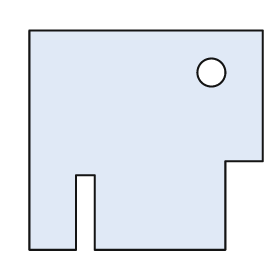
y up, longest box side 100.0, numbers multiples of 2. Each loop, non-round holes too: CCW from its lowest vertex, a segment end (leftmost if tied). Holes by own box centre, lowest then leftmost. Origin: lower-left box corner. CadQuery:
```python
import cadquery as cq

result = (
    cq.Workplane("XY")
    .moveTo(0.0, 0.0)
    .lineTo(20.0, 0.0)
    .lineTo(20.0, 32.0)
    .lineTo(28.0, 32.0)
    .lineTo(28.0, 0.0)
    .lineTo(84.0, 0.0)
    .lineTo(84.0, 38.0)
    .lineTo(100.0, 38.0)
    .lineTo(100.0, 94.0)
    .lineTo(0.0, 94.0)
    .close()
    .moveTo(78.0, 76.0)
    .circle(6.0)
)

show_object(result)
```